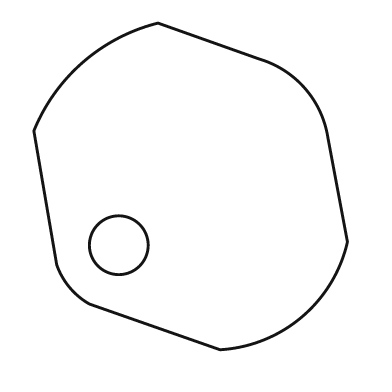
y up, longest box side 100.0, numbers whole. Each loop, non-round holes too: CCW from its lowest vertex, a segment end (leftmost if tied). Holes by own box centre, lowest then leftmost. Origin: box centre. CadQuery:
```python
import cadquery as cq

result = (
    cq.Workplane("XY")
    .moveTo(9.0, -50.0)
    .threePointArc((34.0, -40.0), (48.0, -17.0))
    .lineTo(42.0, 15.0)
    .threePointArc((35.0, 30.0), (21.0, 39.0))
    .lineTo(-10.0, 50.0)
    .threePointArc((-33.0, 38.0), (-48.0, 17.0))
    .lineTo(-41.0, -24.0)
    .threePointArc((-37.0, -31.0), (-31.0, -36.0))
    .close()
    .moveTo(-22.0, -18.0)
    .circle(9.0)
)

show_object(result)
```